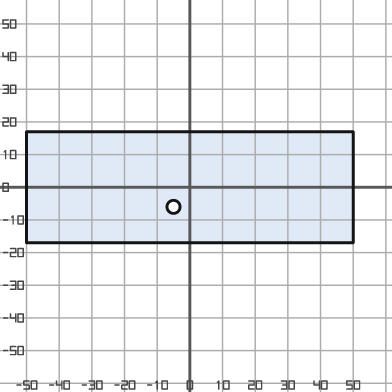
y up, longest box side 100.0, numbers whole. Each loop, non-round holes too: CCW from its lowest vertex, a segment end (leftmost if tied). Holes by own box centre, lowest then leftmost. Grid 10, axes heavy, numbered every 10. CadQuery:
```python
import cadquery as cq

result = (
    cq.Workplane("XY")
    .moveTo(-50.0, -17.0)
    .lineTo(50.0, -17.0)
    .lineTo(50.0, 17.0)
    .lineTo(-50.0, 17.0)
    .close()
    .moveTo(-5.0, -6.0)
    .circle(2.0)
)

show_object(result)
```